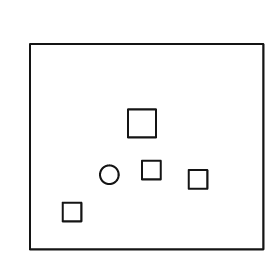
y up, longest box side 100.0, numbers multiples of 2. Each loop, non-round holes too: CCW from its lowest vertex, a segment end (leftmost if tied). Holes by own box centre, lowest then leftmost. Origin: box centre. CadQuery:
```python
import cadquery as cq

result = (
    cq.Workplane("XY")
    .moveTo(-50.0, -44.0)
    .lineTo(50.0, -44.0)
    .lineTo(50.0, 44.0)
    .lineTo(-50.0, 44.0)
    .close()
    .moveTo(-36.0, -32.0)
    .lineTo(-28.0, -32.0)
    .lineTo(-28.0, -24.0)
    .lineTo(-36.0, -24.0)
    .close()
    .moveTo(18.0, -18.0)
    .lineTo(26.0, -18.0)
    .lineTo(26.0, -10.0)
    .lineTo(18.0, -10.0)
    .close()
    .moveTo(-16.0, -12.0)
    .circle(4.0)
    .moveTo(-2.0, -14.0)
    .lineTo(6.0, -14.0)
    .lineTo(6.0, -6.0)
    .lineTo(-2.0, -6.0)
    .close()
    .moveTo(-8.0, 4.0)
    .lineTo(4.0, 4.0)
    .lineTo(4.0, 16.0)
    .lineTo(-8.0, 16.0)
    .close()
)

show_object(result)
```